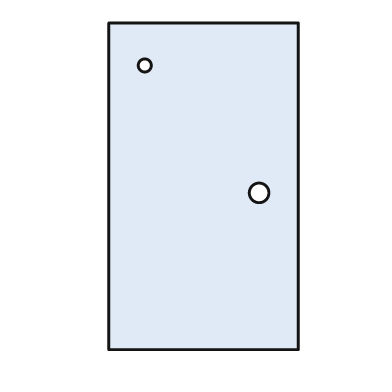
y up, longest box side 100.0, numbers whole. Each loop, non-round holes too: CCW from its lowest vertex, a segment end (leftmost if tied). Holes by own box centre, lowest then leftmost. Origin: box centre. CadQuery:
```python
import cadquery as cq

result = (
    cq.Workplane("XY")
    .moveTo(-29.0, -50.0)
    .lineTo(29.0, -50.0)
    .lineTo(29.0, 50.0)
    .lineTo(-29.0, 50.0)
    .close()
    .moveTo(17.0, -2.0)
    .circle(3.0)
    .moveTo(-18.0, 37.0)
    .circle(2.0)
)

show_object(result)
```